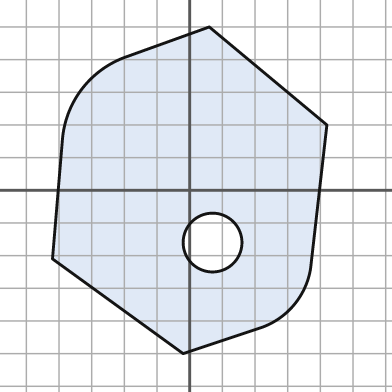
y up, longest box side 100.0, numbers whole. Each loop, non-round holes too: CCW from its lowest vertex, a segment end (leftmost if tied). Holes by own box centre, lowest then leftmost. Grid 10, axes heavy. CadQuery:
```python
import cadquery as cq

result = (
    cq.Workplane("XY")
    .moveTo(-2.0, -50.0)
    .lineTo(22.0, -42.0)
    .threePointArc((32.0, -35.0), (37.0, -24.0))
    .lineTo(42.0, 20.0)
    .lineTo(6.0, 50.0)
    .lineTo(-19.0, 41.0)
    .threePointArc((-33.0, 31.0), (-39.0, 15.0))
    .lineTo(-42.0, -21.0)
    .close()
    .moveTo(7.0, -16.0)
    .circle(9.0)
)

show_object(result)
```